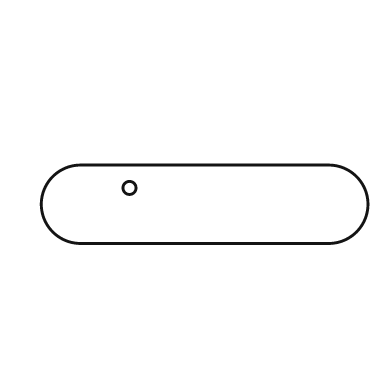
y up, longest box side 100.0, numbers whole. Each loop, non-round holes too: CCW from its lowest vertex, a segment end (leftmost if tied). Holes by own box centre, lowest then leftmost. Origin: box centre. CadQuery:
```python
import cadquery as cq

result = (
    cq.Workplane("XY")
    .moveTo(-38.0, -12.0)
    .lineTo(38.0, -12.0)
    .threePointArc((50.0, 0.0), (38.0, 12.0))
    .lineTo(-38.0, 12.0)
    .threePointArc((-50.0, 0.0), (-38.0, -12.0))
    .close()
    .moveTo(-23.0, 5.0)
    .circle(2.0)
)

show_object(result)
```